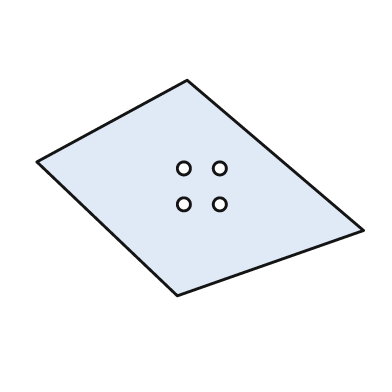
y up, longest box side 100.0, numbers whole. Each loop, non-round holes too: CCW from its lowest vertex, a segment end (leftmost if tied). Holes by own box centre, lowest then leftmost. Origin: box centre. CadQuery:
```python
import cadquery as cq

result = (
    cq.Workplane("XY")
    .moveTo(-7.0, -33.0)
    .lineTo(50.0, -13.0)
    .lineTo(-4.0, 33.0)
    .lineTo(-50.0, 8.0)
    .close()
    .moveTo(-5.0, -5.0)
    .circle(2.0)
    .moveTo(6.0, -5.0)
    .circle(2.0)
    .moveTo(-5.0, 6.0)
    .circle(2.0)
    .moveTo(6.0, 6.0)
    .circle(2.0)
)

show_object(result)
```